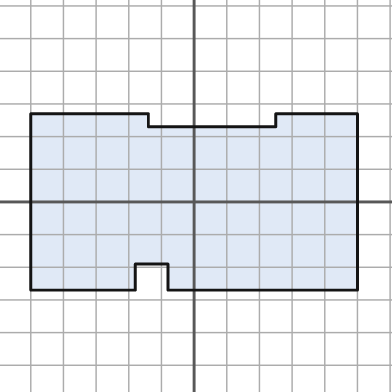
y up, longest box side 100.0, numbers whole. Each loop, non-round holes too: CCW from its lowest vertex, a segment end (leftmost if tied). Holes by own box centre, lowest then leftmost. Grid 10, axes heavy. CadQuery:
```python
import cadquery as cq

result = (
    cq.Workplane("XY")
    .moveTo(-50.0, -27.0)
    .lineTo(-18.0, -27.0)
    .lineTo(-18.0, -19.0)
    .lineTo(-8.0, -19.0)
    .lineTo(-8.0, -27.0)
    .lineTo(50.0, -27.0)
    .lineTo(50.0, 27.0)
    .lineTo(25.0, 27.0)
    .lineTo(25.0, 23.0)
    .lineTo(-14.0, 23.0)
    .lineTo(-14.0, 27.0)
    .lineTo(-50.0, 27.0)
    .close()
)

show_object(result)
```